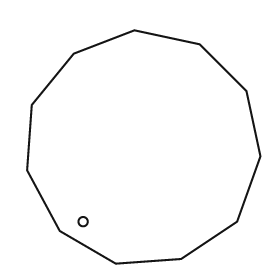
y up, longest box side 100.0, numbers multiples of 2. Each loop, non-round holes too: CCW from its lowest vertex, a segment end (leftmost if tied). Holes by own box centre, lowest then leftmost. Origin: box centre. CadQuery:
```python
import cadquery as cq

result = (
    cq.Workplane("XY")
    .moveTo(-12.0, -50.0)
    .lineTo(16.0, -48.0)
    .lineTo(40.0, -32.0)
    .lineTo(50.0, -4.0)
    .lineTo(44.0, 24.0)
    .lineTo(24.0, 44.0)
    .lineTo(-4.0, 50.0)
    .lineTo(-30.0, 40.0)
    .lineTo(-48.0, 18.0)
    .lineTo(-50.0, -10.0)
    .lineTo(-36.0, -36.0)
    .close()
    .moveTo(-26.0, -32.0)
    .circle(2.0)
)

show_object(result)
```